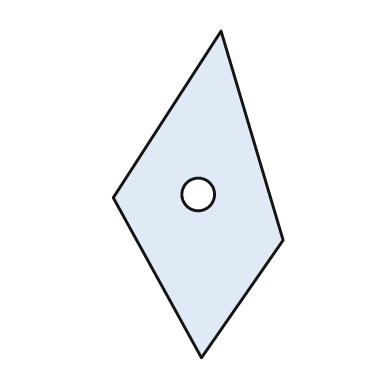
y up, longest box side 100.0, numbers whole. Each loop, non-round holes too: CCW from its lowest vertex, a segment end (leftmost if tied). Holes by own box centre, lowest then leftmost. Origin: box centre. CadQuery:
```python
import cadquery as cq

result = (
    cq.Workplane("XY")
    .moveTo(1.0, -50.0)
    .lineTo(26.0, -14.0)
    .lineTo(7.0, 50.0)
    .lineTo(-26.0, -1.0)
    .close()
    .moveTo(0.0, 0.0)
    .circle(5.0)
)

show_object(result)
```